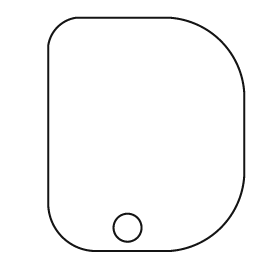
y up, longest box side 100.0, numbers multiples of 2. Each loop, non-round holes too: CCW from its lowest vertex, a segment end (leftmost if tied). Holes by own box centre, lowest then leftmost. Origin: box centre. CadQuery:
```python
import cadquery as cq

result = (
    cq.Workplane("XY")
    .moveTo(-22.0, -50.0)
    .lineTo(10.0, -50.0)
    .threePointArc((32.0, -40.0), (42.0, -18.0))
    .lineTo(42.0, 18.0)
    .threePointArc((32.0, 40.0), (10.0, 50.0))
    .lineTo(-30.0, 50.0)
    .threePointArc((-38.0, 46.0), (-42.0, 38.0))
    .lineTo(-42.0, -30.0)
    .threePointArc((-36.0, -44.0), (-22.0, -50.0))
    .close()
    .moveTo(-8.0, -40.0)
    .circle(6.0)
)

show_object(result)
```